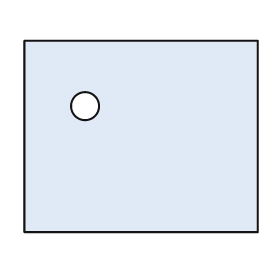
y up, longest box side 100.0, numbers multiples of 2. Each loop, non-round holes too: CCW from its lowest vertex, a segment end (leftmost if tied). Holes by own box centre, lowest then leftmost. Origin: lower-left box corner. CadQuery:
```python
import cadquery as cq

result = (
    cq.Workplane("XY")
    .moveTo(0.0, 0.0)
    .lineTo(100.0, 0.0)
    .lineTo(100.0, 82.0)
    .lineTo(0.0, 82.0)
    .close()
    .moveTo(26.0, 54.0)
    .circle(6.0)
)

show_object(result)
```